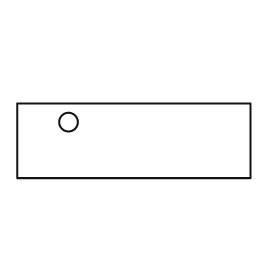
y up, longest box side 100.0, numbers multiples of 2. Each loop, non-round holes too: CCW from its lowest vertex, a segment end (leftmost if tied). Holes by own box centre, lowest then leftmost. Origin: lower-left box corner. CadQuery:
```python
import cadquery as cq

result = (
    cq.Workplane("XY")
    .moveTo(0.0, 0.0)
    .lineTo(100.0, 0.0)
    .lineTo(100.0, 32.0)
    .lineTo(0.0, 32.0)
    .close()
    .moveTo(22.0, 24.0)
    .circle(4.0)
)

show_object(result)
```